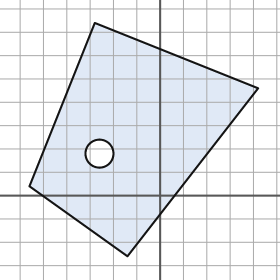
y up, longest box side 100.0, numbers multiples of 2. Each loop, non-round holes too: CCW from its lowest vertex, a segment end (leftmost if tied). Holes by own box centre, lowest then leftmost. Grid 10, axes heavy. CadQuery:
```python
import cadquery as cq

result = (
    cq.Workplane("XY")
    .moveTo(-14.0, -26.0)
    .lineTo(42.0, 46.0)
    .lineTo(-28.0, 74.0)
    .lineTo(-56.0, 4.0)
    .close()
    .moveTo(-26.0, 18.0)
    .circle(6.0)
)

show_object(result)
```